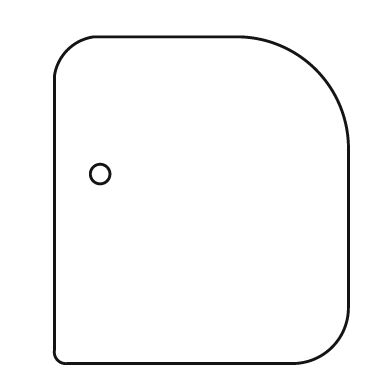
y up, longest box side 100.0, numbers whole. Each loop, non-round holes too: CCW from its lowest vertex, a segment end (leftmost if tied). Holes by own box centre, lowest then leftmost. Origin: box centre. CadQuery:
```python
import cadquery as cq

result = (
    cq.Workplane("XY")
    .moveTo(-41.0, -50.0)
    .lineTo(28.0, -50.0)
    .threePointArc((40.0, -45.0), (45.0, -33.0))
    .lineTo(45.0, 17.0)
    .threePointArc((35.0, 40.0), (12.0, 50.0))
    .lineTo(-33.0, 50.0)
    .threePointArc((-41.0, 46.0), (-45.0, 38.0))
    .lineTo(-45.0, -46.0)
    .threePointArc((-44.0, -49.0), (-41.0, -50.0))
    .close()
    .moveTo(-31.0, 8.0)
    .circle(3.0)
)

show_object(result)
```